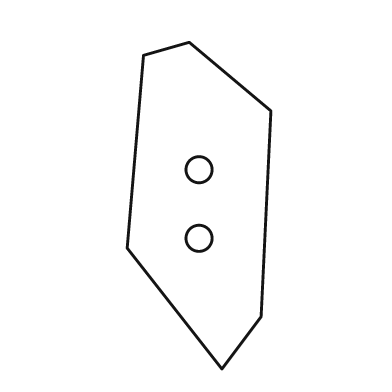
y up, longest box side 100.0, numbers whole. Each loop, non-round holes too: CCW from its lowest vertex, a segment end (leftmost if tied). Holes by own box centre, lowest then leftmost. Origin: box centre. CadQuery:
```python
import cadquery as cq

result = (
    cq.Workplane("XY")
    .moveTo(7.0, -50.0)
    .lineTo(19.0, -34.0)
    .lineTo(22.0, 29.0)
    .lineTo(-3.0, 50.0)
    .lineTo(-17.0, 46.0)
    .lineTo(-22.0, -13.0)
    .close()
    .moveTo(0.0, -10.0)
    .circle(4.0)
    .moveTo(0.0, 11.0)
    .circle(4.0)
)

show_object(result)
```